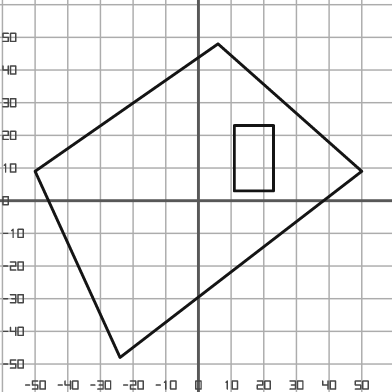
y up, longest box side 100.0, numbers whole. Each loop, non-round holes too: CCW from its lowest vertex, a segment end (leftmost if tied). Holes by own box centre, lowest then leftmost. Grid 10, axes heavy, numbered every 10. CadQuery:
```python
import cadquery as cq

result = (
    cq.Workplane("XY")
    .moveTo(-24.0, -48.0)
    .lineTo(50.0, 9.0)
    .lineTo(6.0, 48.0)
    .lineTo(-50.0, 9.0)
    .close()
    .moveTo(11.0, 3.0)
    .lineTo(23.0, 3.0)
    .lineTo(23.0, 23.0)
    .lineTo(11.0, 23.0)
    .close()
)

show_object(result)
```